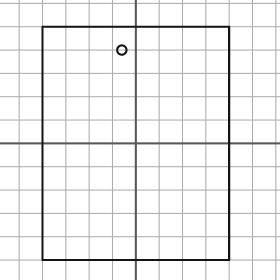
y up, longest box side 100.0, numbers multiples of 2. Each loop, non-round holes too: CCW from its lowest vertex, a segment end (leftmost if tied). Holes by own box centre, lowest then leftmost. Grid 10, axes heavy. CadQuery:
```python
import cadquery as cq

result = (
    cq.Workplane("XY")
    .moveTo(-40.0, -50.0)
    .lineTo(40.0, -50.0)
    .lineTo(40.0, 50.0)
    .lineTo(-40.0, 50.0)
    .close()
    .moveTo(-6.0, 40.0)
    .circle(2.0)
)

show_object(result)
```